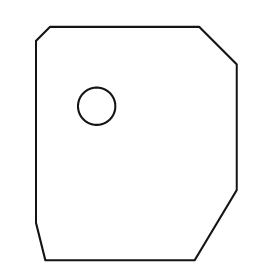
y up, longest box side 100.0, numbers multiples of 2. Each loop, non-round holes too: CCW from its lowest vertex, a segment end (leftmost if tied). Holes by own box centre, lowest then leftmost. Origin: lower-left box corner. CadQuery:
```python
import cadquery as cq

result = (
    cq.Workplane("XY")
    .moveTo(4.0, 0.0)
    .lineTo(68.0, 0.0)
    .lineTo(86.0, 30.0)
    .lineTo(86.0, 84.0)
    .lineTo(70.0, 100.0)
    .lineTo(6.0, 100.0)
    .lineTo(0.0, 94.0)
    .lineTo(0.0, 16.0)
    .close()
    .moveTo(26.0, 66.0)
    .circle(8.0)
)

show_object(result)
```